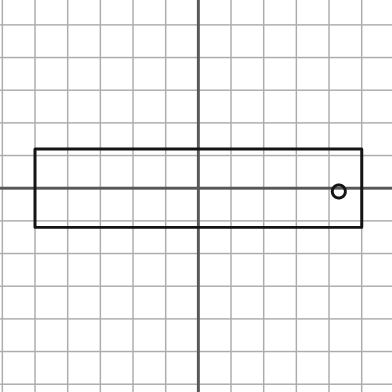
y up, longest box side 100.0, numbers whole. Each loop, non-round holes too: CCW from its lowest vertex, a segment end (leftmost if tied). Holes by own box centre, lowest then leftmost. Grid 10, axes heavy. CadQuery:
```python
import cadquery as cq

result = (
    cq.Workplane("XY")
    .moveTo(-50.0, -12.0)
    .lineTo(50.0, -12.0)
    .lineTo(50.0, 12.0)
    .lineTo(-50.0, 12.0)
    .close()
    .moveTo(43.0, -1.0)
    .circle(2.0)
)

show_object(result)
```